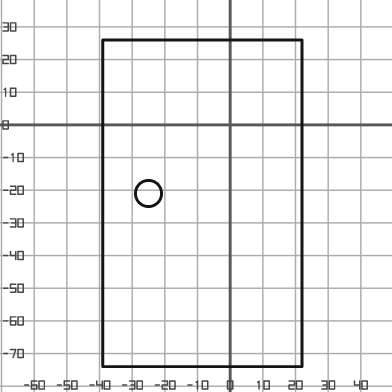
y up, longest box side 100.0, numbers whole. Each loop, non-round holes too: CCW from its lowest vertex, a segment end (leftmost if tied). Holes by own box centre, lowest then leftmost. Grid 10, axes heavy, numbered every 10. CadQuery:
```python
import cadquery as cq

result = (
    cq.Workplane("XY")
    .moveTo(-39.0, -74.0)
    .lineTo(22.0, -74.0)
    .lineTo(22.0, 26.0)
    .lineTo(-39.0, 26.0)
    .close()
    .moveTo(-25.0, -21.0)
    .circle(4.0)
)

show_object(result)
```